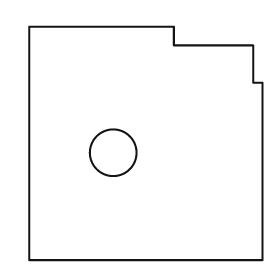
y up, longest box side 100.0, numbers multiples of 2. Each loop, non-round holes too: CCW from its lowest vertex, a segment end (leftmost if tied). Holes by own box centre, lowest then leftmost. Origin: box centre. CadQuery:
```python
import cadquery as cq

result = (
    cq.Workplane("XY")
    .moveTo(-50.0, -50.0)
    .lineTo(50.0, -50.0)
    .lineTo(50.0, 26.0)
    .lineTo(46.0, 26.0)
    .lineTo(46.0, 42.0)
    .lineTo(12.0, 42.0)
    .lineTo(12.0, 50.0)
    .lineTo(-50.0, 50.0)
    .close()
    .moveTo(-14.0, -4.0)
    .circle(10.0)
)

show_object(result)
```